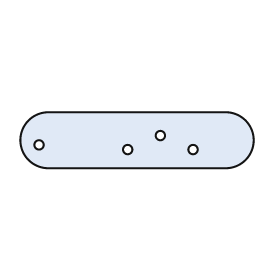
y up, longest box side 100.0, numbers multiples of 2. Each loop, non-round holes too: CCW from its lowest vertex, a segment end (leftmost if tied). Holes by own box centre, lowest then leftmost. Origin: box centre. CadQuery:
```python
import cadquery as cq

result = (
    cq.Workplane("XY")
    .moveTo(-38.0, -12.0)
    .lineTo(38.0, -12.0)
    .threePointArc((50.0, 0.0), (38.0, 12.0))
    .lineTo(-38.0, 12.0)
    .threePointArc((-50.0, 0.0), (-38.0, -12.0))
    .close()
    .moveTo(-4.0, -4.0)
    .circle(2.0)
    .moveTo(24.0, -4.0)
    .circle(2.0)
    .moveTo(-42.0, -2.0)
    .circle(2.0)
    .moveTo(10.0, 2.0)
    .circle(2.0)
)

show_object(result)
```